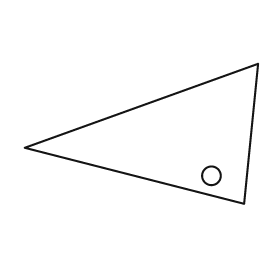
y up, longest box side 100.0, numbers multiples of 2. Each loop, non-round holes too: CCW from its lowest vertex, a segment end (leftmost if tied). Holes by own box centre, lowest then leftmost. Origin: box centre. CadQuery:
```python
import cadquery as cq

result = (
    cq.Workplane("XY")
    .moveTo(44.0, -30.0)
    .lineTo(50.0, 30.0)
    .lineTo(-50.0, -6.0)
    .close()
    .moveTo(30.0, -18.0)
    .circle(4.0)
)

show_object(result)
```